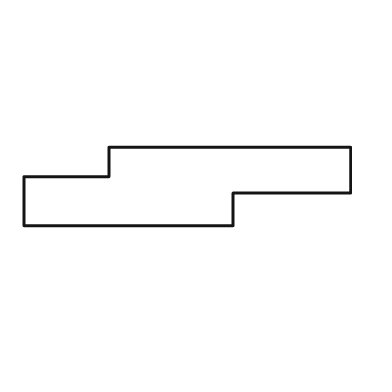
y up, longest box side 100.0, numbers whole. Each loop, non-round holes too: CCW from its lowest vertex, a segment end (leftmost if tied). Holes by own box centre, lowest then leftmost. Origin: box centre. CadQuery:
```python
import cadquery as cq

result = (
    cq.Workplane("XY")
    .moveTo(-50.0, -12.0)
    .lineTo(14.0, -12.0)
    .lineTo(14.0, -2.0)
    .lineTo(50.0, -2.0)
    .lineTo(50.0, 12.0)
    .lineTo(-24.0, 12.0)
    .lineTo(-24.0, 3.0)
    .lineTo(-50.0, 3.0)
    .close()
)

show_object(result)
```